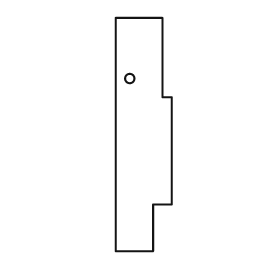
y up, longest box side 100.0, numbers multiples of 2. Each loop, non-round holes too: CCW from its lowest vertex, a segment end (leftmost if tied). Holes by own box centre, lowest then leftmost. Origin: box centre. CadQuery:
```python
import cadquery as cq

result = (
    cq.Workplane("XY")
    .moveTo(-12.0, -50.0)
    .lineTo(4.0, -50.0)
    .lineTo(4.0, -30.0)
    .lineTo(12.0, -30.0)
    .lineTo(12.0, 16.0)
    .lineTo(8.0, 16.0)
    .lineTo(8.0, 50.0)
    .lineTo(-12.0, 50.0)
    .close()
    .moveTo(-6.0, 24.0)
    .circle(2.0)
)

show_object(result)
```